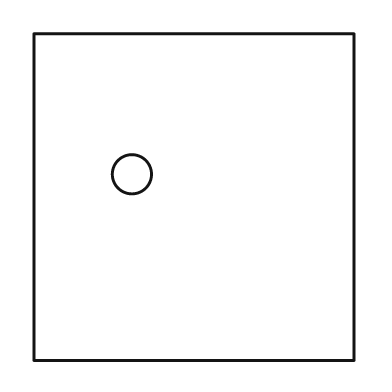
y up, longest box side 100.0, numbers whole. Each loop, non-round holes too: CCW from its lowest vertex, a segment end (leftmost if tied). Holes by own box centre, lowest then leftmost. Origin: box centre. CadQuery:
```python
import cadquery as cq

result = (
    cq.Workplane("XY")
    .moveTo(-49.0, -50.0)
    .lineTo(49.0, -50.0)
    .lineTo(49.0, 50.0)
    .lineTo(-49.0, 50.0)
    .close()
    .moveTo(-19.0, 7.0)
    .circle(6.0)
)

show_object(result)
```